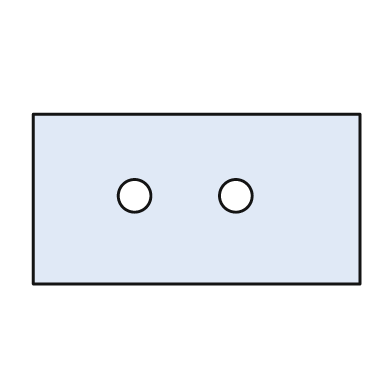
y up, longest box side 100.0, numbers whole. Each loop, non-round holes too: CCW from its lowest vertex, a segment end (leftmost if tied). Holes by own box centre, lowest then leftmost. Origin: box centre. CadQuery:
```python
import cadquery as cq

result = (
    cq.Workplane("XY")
    .moveTo(-50.0, -26.0)
    .lineTo(50.0, -26.0)
    .lineTo(50.0, 26.0)
    .lineTo(-50.0, 26.0)
    .close()
    .moveTo(-19.0, 1.0)
    .circle(5.0)
    .moveTo(12.0, 1.0)
    .circle(5.0)
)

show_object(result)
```